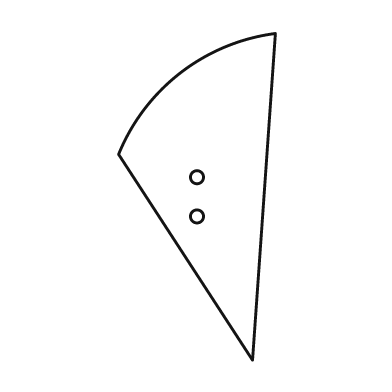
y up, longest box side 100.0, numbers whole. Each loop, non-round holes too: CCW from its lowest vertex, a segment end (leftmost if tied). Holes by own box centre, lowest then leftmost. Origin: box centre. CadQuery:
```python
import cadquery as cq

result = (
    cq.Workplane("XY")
    .moveTo(17.0, -50.0)
    .lineTo(24.0, 50.0)
    .threePointArc((-5.0, 38.0), (-24.0, 13.0))
    .close()
    .moveTo(0.0, -6.0)
    .circle(2.0)
    .moveTo(0.0, 6.0)
    .circle(2.0)
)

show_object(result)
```